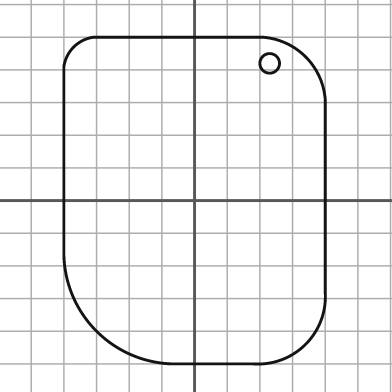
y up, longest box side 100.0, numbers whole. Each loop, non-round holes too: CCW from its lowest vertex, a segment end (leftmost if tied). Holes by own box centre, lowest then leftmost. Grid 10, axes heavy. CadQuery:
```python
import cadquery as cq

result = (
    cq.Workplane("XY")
    .moveTo(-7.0, -50.0)
    .lineTo(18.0, -50.0)
    .threePointArc((34.0, -44.0), (40.0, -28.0))
    .lineTo(40.0, 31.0)
    .threePointArc((34.0, 44.0), (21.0, 50.0))
    .lineTo(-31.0, 50.0)
    .threePointArc((-37.0, 47.0), (-40.0, 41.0))
    .lineTo(-40.0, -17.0)
    .threePointArc((-30.0, -40.0), (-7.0, -50.0))
    .close()
    .moveTo(23.0, 42.0)
    .circle(3.0)
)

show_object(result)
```